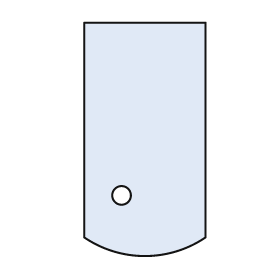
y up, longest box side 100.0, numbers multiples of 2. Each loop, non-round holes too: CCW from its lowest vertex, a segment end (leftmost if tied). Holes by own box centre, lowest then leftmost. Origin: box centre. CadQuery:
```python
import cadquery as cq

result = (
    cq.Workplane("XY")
    .moveTo(-26.0, -42.0)
    .threePointArc((0.0, -50.0), (26.0, -42.0))
    .lineTo(26.0, 50.0)
    .lineTo(-26.0, 50.0)
    .close()
    .moveTo(-10.0, -24.0)
    .circle(4.0)
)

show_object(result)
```